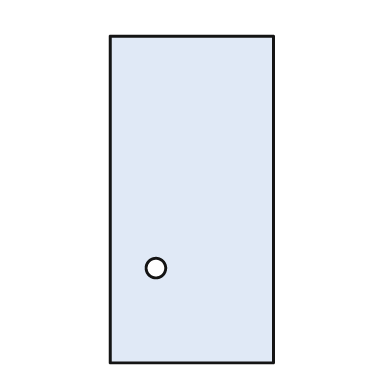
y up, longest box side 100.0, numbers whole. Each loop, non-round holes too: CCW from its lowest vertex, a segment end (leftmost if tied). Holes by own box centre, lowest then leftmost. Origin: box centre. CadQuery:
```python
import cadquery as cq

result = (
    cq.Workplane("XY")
    .moveTo(-25.0, -50.0)
    .lineTo(25.0, -50.0)
    .lineTo(25.0, 50.0)
    .lineTo(-25.0, 50.0)
    .close()
    .moveTo(-11.0, -21.0)
    .circle(3.0)
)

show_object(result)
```